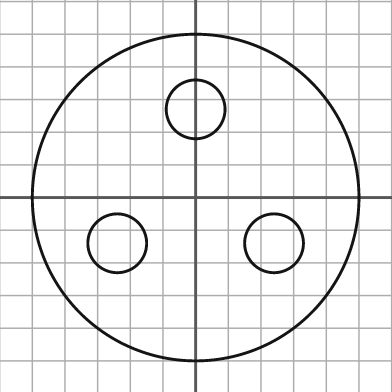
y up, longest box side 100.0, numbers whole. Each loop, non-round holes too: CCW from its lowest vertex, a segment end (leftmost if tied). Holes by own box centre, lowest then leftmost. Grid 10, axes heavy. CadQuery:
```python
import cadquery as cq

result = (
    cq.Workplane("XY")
    .moveTo(0.0, 0.0)
    .circle(50.0)
    .moveTo(-24.0, -14.0)
    .circle(9.0)
    .moveTo(24.0, -14.0)
    .circle(9.0)
    .moveTo(0.0, 27.0)
    .circle(9.0)
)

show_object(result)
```